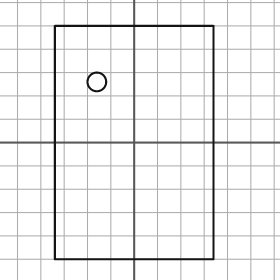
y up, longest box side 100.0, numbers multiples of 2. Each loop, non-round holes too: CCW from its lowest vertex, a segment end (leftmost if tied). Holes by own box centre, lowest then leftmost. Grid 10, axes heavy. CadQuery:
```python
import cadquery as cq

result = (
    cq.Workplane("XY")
    .moveTo(-34.0, -50.0)
    .lineTo(34.0, -50.0)
    .lineTo(34.0, 50.0)
    .lineTo(-34.0, 50.0)
    .close()
    .moveTo(-16.0, 26.0)
    .circle(4.0)
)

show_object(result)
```